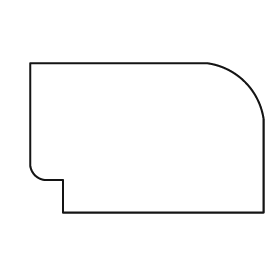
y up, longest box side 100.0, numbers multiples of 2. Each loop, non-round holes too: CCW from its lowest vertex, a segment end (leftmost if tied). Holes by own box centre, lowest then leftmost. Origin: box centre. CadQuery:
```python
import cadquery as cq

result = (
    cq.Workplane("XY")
    .moveTo(-36.0, -32.0)
    .lineTo(50.0, -32.0)
    .lineTo(50.0, 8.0)
    .threePointArc((42.0, 24.0), (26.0, 32.0))
    .lineTo(-50.0, 32.0)
    .lineTo(-50.0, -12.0)
    .threePointArc((-48.0, -16.0), (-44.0, -18.0))
    .lineTo(-36.0, -18.0)
    .close()
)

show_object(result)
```